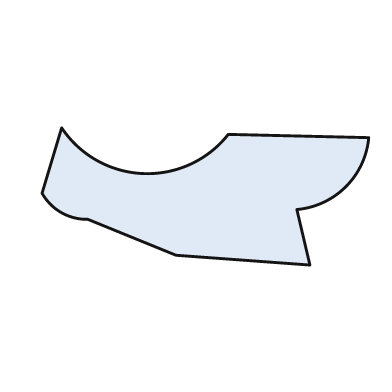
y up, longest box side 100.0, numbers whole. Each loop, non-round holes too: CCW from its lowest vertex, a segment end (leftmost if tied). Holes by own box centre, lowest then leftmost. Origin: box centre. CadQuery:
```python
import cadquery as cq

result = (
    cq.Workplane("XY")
    .moveTo(32.0, -21.0)
    .lineTo(28.0, -4.0)
    .threePointArc((43.0, 3.0), (50.0, 18.0))
    .lineTo(7.0, 19.0)
    .threePointArc((-19.0, 7.0), (-44.0, 21.0))
    .lineTo(-50.0, 1.0)
    .threePointArc((-44.0, -5.0), (-36.0, -7.0))
    .lineTo(-9.0, -18.0)
    .close()
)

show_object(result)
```